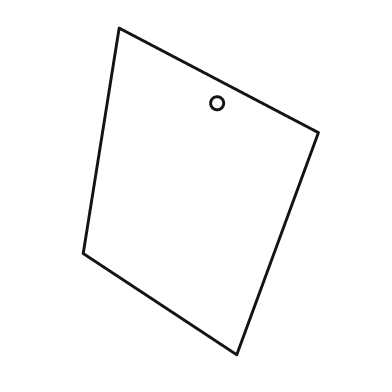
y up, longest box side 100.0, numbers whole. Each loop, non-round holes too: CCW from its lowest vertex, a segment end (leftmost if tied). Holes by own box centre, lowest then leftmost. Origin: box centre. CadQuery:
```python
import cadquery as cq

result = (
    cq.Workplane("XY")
    .moveTo(11.0, -50.0)
    .lineTo(36.0, 18.0)
    .lineTo(-25.0, 50.0)
    .lineTo(-36.0, -19.0)
    .close()
    .moveTo(5.0, 27.0)
    .circle(2.0)
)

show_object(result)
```